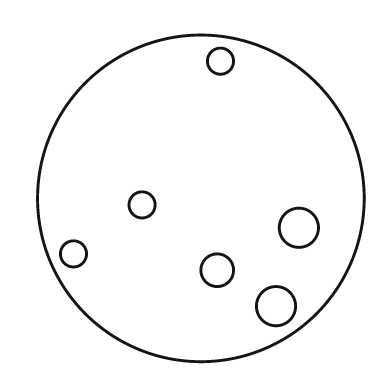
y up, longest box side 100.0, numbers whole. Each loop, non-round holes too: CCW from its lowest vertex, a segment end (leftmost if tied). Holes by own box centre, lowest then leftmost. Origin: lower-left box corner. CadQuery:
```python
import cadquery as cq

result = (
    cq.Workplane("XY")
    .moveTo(50.0, 50.0)
    .circle(50.0)
    .moveTo(73.0, 17.0)
    .circle(6.0)
    .moveTo(55.0, 28.0)
    .circle(5.0)
    .moveTo(11.0, 33.0)
    .circle(4.0)
    .moveTo(80.0, 41.0)
    .circle(6.0)
    .moveTo(32.0, 48.0)
    .circle(4.0)
    .moveTo(56.0, 92.0)
    .circle(4.0)
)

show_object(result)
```